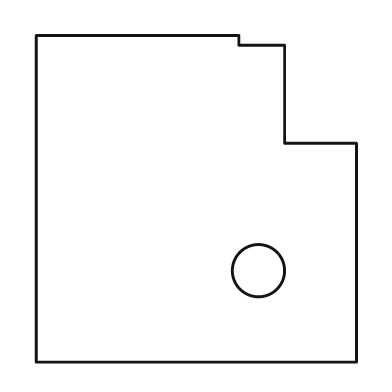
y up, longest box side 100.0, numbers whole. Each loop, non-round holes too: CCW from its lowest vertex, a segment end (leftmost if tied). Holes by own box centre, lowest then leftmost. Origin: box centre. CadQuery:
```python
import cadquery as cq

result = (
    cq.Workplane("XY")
    .moveTo(-49.0, -50.0)
    .lineTo(49.0, -50.0)
    .lineTo(49.0, 17.0)
    .lineTo(27.0, 17.0)
    .lineTo(27.0, 47.0)
    .lineTo(13.0, 47.0)
    .lineTo(13.0, 50.0)
    .lineTo(-49.0, 50.0)
    .close()
    .moveTo(19.0, -22.0)
    .circle(8.0)
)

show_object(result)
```